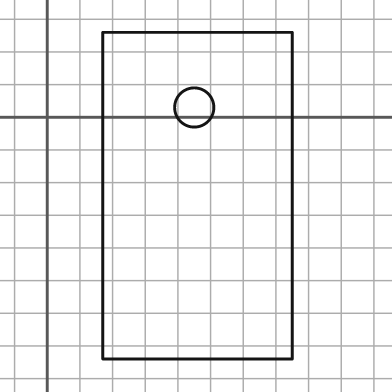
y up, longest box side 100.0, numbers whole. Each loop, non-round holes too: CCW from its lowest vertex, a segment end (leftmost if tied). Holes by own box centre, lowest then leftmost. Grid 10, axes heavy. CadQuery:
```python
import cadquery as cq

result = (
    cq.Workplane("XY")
    .moveTo(17.0, -74.0)
    .lineTo(75.0, -74.0)
    .lineTo(75.0, 26.0)
    .lineTo(17.0, 26.0)
    .close()
    .moveTo(45.0, 3.0)
    .circle(6.0)
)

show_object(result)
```